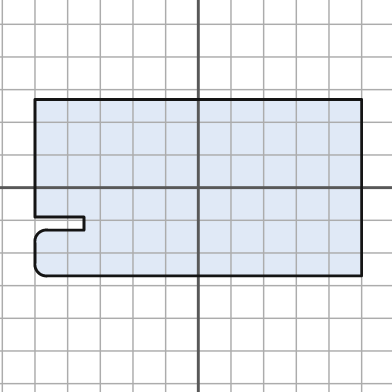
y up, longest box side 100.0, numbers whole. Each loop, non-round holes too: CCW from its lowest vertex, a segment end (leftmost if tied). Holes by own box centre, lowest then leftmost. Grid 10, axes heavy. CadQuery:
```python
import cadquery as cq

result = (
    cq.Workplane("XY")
    .moveTo(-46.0, -27.0)
    .lineTo(50.0, -27.0)
    .lineTo(50.0, 27.0)
    .lineTo(-50.0, 27.0)
    .lineTo(-50.0, -9.0)
    .lineTo(-35.0, -9.0)
    .lineTo(-35.0, -13.0)
    .lineTo(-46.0, -13.0)
    .threePointArc((-49.0, -14.0), (-50.0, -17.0))
    .lineTo(-50.0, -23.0)
    .threePointArc((-49.0, -26.0), (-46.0, -27.0))
    .close()
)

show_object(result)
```